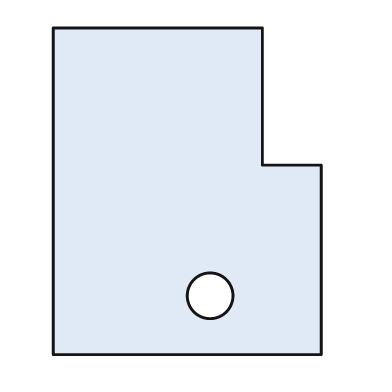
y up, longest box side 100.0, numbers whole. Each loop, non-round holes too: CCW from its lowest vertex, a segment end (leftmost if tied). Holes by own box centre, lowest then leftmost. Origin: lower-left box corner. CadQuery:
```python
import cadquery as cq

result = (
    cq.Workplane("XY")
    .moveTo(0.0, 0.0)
    .lineTo(82.0, 0.0)
    .lineTo(82.0, 58.0)
    .lineTo(64.0, 58.0)
    .lineTo(64.0, 100.0)
    .lineTo(0.0, 100.0)
    .close()
    .moveTo(48.0, 18.0)
    .circle(7.0)
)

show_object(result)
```